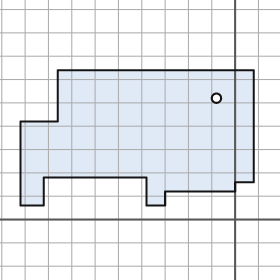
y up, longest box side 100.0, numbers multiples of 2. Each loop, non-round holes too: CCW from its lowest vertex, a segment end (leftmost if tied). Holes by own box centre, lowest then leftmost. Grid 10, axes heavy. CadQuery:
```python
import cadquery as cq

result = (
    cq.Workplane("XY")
    .moveTo(-92.0, 6.0)
    .lineTo(-82.0, 6.0)
    .lineTo(-82.0, 18.0)
    .lineTo(-38.0, 18.0)
    .lineTo(-38.0, 6.0)
    .lineTo(-30.0, 6.0)
    .lineTo(-30.0, 12.0)
    .lineTo(0.0, 12.0)
    .lineTo(0.0, 16.0)
    .lineTo(8.0, 16.0)
    .lineTo(8.0, 64.0)
    .lineTo(-76.0, 64.0)
    .lineTo(-76.0, 42.0)
    .lineTo(-92.0, 42.0)
    .close()
    .moveTo(-8.0, 52.0)
    .circle(2.0)
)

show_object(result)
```